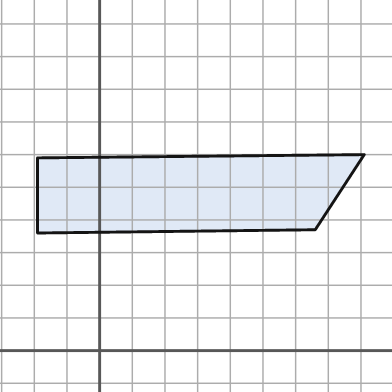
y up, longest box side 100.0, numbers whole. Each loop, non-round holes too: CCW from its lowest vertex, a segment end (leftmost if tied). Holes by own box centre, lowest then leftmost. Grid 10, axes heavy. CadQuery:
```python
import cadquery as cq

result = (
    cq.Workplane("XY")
    .moveTo(-19.0, 36.0)
    .lineTo(66.0, 37.0)
    .lineTo(81.0, 60.0)
    .lineTo(-19.0, 59.0)
    .close()
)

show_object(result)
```